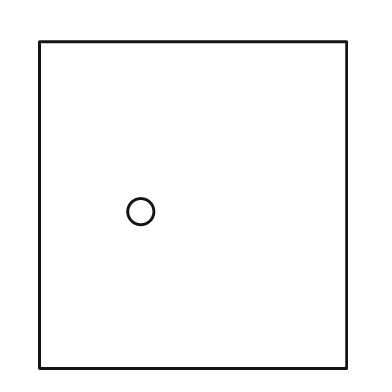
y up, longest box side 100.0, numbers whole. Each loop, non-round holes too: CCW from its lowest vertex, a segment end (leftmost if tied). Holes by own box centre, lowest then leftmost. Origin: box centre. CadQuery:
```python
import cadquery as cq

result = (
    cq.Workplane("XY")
    .moveTo(-47.0, -50.0)
    .lineTo(47.0, -50.0)
    .lineTo(47.0, 50.0)
    .lineTo(-47.0, 50.0)
    .close()
    .moveTo(-16.0, -2.0)
    .circle(4.0)
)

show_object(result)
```